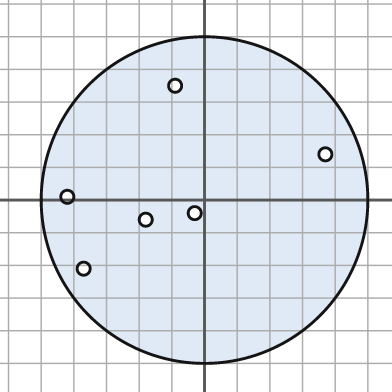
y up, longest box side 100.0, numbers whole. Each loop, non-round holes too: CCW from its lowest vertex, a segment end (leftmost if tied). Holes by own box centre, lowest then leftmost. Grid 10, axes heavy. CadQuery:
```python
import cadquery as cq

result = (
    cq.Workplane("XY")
    .moveTo(0.0, 0.0)
    .circle(50.0)
    .moveTo(-37.0, -21.0)
    .circle(2.0)
    .moveTo(-18.0, -6.0)
    .circle(2.0)
    .moveTo(-3.0, -4.0)
    .circle(2.0)
    .moveTo(-42.0, 1.0)
    .circle(2.0)
    .moveTo(37.0, 14.0)
    .circle(2.0)
    .moveTo(-9.0, 35.0)
    .circle(2.0)
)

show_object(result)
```